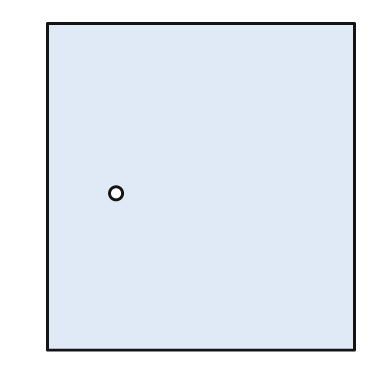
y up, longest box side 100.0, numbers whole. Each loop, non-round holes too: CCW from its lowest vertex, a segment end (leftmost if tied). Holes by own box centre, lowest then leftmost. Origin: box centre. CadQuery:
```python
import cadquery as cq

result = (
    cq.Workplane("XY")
    .moveTo(-47.0, -50.0)
    .lineTo(47.0, -50.0)
    .lineTo(47.0, 50.0)
    .lineTo(-47.0, 50.0)
    .close()
    .moveTo(-26.0, -2.0)
    .circle(2.0)
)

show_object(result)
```